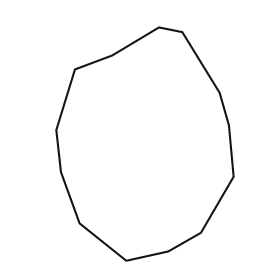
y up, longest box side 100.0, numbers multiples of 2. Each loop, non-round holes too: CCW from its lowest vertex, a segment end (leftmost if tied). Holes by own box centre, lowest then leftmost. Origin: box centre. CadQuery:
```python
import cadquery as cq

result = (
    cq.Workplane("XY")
    .moveTo(-8.0, -50.0)
    .lineTo(10.0, -46.0)
    .lineTo(24.0, -38.0)
    .lineTo(38.0, -14.0)
    .lineTo(36.0, 8.0)
    .lineTo(32.0, 22.0)
    .lineTo(16.0, 48.0)
    .lineTo(6.0, 50.0)
    .lineTo(-14.0, 38.0)
    .lineTo(-30.0, 32.0)
    .lineTo(-38.0, 6.0)
    .lineTo(-36.0, -12.0)
    .lineTo(-28.0, -34.0)
    .close()
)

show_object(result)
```